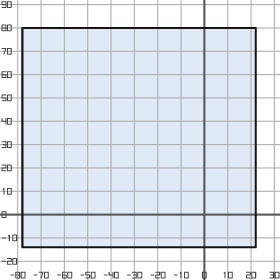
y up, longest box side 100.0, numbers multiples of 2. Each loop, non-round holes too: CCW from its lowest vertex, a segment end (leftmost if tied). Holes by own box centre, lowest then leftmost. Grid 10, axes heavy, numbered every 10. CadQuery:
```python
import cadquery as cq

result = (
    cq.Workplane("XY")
    .moveTo(-78.0, -14.0)
    .lineTo(22.0, -14.0)
    .lineTo(22.0, 80.0)
    .lineTo(-78.0, 80.0)
    .close()
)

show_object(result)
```